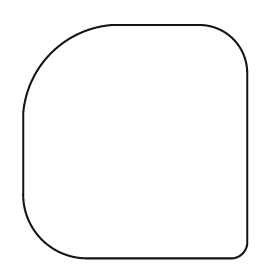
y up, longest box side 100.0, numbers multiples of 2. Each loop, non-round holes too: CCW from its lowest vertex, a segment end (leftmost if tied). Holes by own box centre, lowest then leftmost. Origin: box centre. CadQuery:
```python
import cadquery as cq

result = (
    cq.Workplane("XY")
    .moveTo(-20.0, -50.0)
    .lineTo(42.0, -50.0)
    .threePointArc((46.0, -48.0), (48.0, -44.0))
    .lineTo(48.0, 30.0)
    .threePointArc((42.0, 44.0), (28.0, 50.0))
    .lineTo(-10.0, 50.0)
    .threePointArc((-36.0, 38.0), (-48.0, 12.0))
    .lineTo(-48.0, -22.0)
    .threePointArc((-40.0, -42.0), (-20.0, -50.0))
    .close()
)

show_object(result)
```